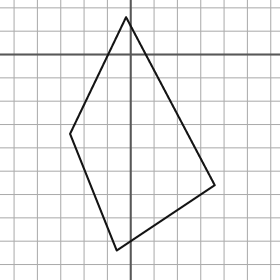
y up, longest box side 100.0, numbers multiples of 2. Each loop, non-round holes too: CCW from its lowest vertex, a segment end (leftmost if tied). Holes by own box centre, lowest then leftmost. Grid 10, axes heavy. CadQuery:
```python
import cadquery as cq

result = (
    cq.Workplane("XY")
    .moveTo(-6.0, -84.0)
    .lineTo(36.0, -56.0)
    .lineTo(-2.0, 16.0)
    .lineTo(-26.0, -34.0)
    .close()
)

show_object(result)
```